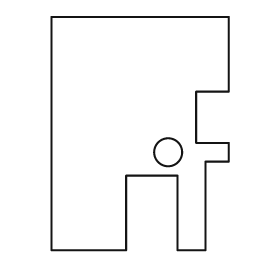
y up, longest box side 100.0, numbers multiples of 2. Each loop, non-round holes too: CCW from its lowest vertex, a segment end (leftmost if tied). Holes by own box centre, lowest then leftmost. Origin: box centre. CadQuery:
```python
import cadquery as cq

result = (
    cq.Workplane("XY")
    .moveTo(-38.0, -50.0)
    .lineTo(-6.0, -50.0)
    .lineTo(-6.0, -18.0)
    .lineTo(16.0, -18.0)
    .lineTo(16.0, -50.0)
    .lineTo(28.0, -50.0)
    .lineTo(28.0, -12.0)
    .lineTo(38.0, -12.0)
    .lineTo(38.0, -4.0)
    .lineTo(24.0, -4.0)
    .lineTo(24.0, 18.0)
    .lineTo(38.0, 18.0)
    .lineTo(38.0, 50.0)
    .lineTo(-38.0, 50.0)
    .close()
    .moveTo(12.0, -8.0)
    .circle(6.0)
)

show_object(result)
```